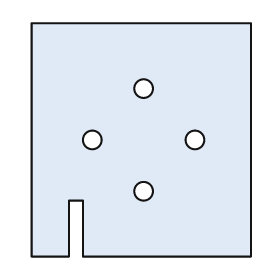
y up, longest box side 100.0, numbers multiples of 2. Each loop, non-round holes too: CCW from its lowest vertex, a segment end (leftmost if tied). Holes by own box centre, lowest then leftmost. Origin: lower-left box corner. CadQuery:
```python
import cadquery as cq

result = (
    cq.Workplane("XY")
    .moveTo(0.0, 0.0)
    .lineTo(16.0, 0.0)
    .lineTo(16.0, 24.0)
    .lineTo(22.0, 24.0)
    .lineTo(22.0, 0.0)
    .lineTo(94.0, 0.0)
    .lineTo(94.0, 100.0)
    .lineTo(0.0, 100.0)
    .close()
    .moveTo(48.0, 28.0)
    .circle(4.0)
    .moveTo(26.0, 50.0)
    .circle(4.0)
    .moveTo(70.0, 50.0)
    .circle(4.0)
    .moveTo(48.0, 72.0)
    .circle(4.0)
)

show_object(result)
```